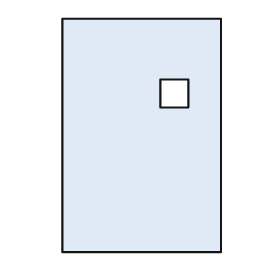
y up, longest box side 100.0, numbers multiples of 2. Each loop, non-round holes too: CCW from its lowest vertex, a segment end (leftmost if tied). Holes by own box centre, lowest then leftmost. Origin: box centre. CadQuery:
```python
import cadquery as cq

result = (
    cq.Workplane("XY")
    .moveTo(-34.0, -50.0)
    .lineTo(34.0, -50.0)
    .lineTo(34.0, 50.0)
    .lineTo(-34.0, 50.0)
    .close()
    .moveTo(8.0, 12.0)
    .lineTo(20.0, 12.0)
    .lineTo(20.0, 24.0)
    .lineTo(8.0, 24.0)
    .close()
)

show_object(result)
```